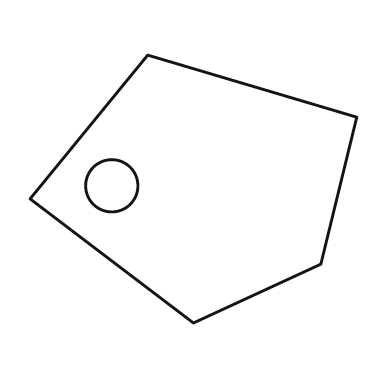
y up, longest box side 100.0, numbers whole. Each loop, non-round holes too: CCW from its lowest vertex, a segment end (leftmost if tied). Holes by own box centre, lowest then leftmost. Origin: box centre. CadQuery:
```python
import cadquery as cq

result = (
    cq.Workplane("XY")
    .moveTo(0.0, -41.0)
    .lineTo(39.0, -23.0)
    .lineTo(50.0, 22.0)
    .lineTo(-14.0, 41.0)
    .lineTo(-50.0, -3.0)
    .close()
    .moveTo(-25.0, 1.0)
    .circle(8.0)
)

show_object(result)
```